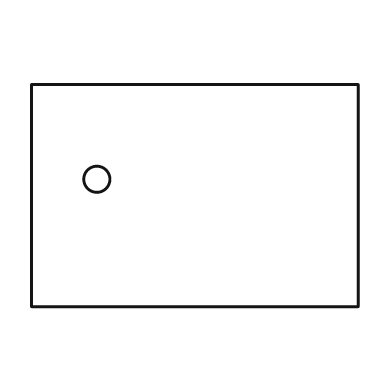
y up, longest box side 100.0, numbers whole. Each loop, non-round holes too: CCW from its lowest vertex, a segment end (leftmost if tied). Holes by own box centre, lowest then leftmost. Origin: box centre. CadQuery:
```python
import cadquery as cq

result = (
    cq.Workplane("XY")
    .moveTo(-50.0, -34.0)
    .lineTo(50.0, -34.0)
    .lineTo(50.0, 34.0)
    .lineTo(-50.0, 34.0)
    .close()
    .moveTo(-30.0, 5.0)
    .circle(4.0)
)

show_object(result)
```